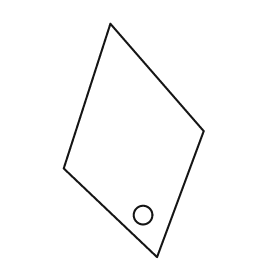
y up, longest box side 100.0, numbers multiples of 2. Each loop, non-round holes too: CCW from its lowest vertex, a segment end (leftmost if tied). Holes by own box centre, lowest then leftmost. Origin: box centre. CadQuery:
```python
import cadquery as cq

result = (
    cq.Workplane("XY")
    .moveTo(10.0, -50.0)
    .lineTo(30.0, 4.0)
    .lineTo(-10.0, 50.0)
    .lineTo(-30.0, -12.0)
    .close()
    .moveTo(4.0, -32.0)
    .circle(4.0)
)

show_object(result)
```